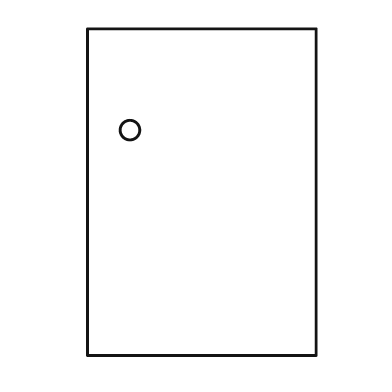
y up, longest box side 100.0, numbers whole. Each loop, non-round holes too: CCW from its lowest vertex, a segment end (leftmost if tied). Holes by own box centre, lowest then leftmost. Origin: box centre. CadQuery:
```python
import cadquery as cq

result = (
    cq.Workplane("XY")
    .moveTo(-35.0, -50.0)
    .lineTo(35.0, -50.0)
    .lineTo(35.0, 50.0)
    .lineTo(-35.0, 50.0)
    .close()
    .moveTo(-22.0, 19.0)
    .circle(3.0)
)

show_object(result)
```